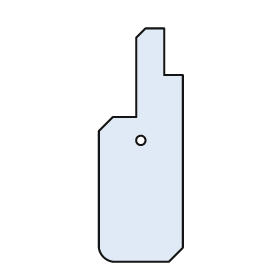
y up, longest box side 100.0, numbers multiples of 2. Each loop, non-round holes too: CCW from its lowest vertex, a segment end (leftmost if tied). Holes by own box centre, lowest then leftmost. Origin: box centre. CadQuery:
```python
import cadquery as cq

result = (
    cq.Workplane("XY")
    .moveTo(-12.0, -50.0)
    .lineTo(12.0, -50.0)
    .lineTo(18.0, -44.0)
    .lineTo(18.0, 30.0)
    .lineTo(10.0, 30.0)
    .lineTo(10.0, 50.0)
    .lineTo(2.0, 50.0)
    .lineTo(-2.0, 46.0)
    .lineTo(-2.0, 12.0)
    .lineTo(-12.0, 12.0)
    .lineTo(-18.0, 6.0)
    .lineTo(-18.0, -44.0)
    .threePointArc((-16.0, -48.0), (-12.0, -50.0))
    .close()
    .moveTo(0.0, 2.0)
    .circle(2.0)
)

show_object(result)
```